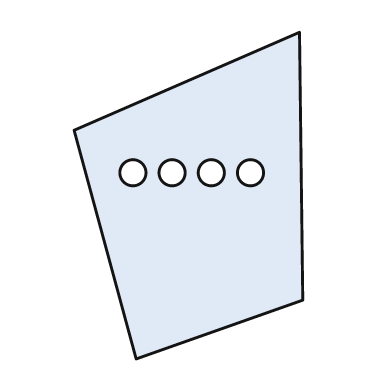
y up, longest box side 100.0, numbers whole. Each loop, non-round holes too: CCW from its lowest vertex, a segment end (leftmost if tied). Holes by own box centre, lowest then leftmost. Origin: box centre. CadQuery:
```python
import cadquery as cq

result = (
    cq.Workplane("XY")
    .moveTo(-16.0, -50.0)
    .lineTo(35.0, -32.0)
    .lineTo(34.0, 50.0)
    .lineTo(-35.0, 20.0)
    .close()
    .moveTo(-17.0, 7.0)
    .circle(4.0)
    .moveTo(-5.0, 7.0)
    .circle(4.0)
    .moveTo(7.0, 7.0)
    .circle(4.0)
    .moveTo(19.0, 7.0)
    .circle(4.0)
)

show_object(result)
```